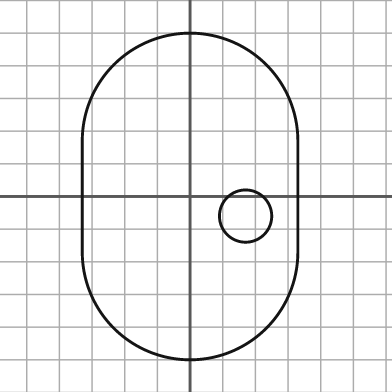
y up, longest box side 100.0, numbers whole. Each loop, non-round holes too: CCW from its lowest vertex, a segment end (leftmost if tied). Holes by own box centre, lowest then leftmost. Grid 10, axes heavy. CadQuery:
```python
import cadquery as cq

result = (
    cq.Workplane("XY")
    .moveTo(-33.0, -17.0)
    .threePointArc((0.0, -50.0), (33.0, -17.0))
    .lineTo(33.0, 17.0)
    .threePointArc((0.0, 50.0), (-33.0, 17.0))
    .close()
    .moveTo(17.0, -6.0)
    .circle(8.0)
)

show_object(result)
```